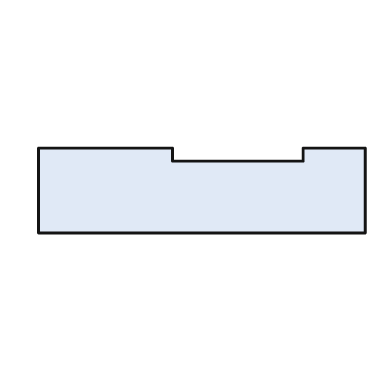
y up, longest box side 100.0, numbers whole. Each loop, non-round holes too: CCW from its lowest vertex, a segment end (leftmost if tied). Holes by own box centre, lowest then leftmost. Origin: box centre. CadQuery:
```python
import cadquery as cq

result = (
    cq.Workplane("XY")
    .moveTo(-50.0, -13.0)
    .lineTo(50.0, -13.0)
    .lineTo(50.0, 13.0)
    .lineTo(31.0, 13.0)
    .lineTo(31.0, 9.0)
    .lineTo(-9.0, 9.0)
    .lineTo(-9.0, 13.0)
    .lineTo(-50.0, 13.0)
    .close()
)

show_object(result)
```